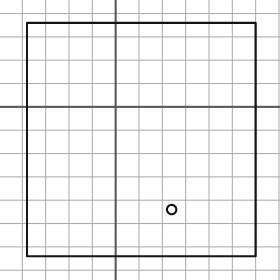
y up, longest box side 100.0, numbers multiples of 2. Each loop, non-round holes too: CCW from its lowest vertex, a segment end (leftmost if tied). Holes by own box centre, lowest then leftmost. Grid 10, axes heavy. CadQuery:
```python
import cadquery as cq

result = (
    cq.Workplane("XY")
    .moveTo(-38.0, -64.0)
    .lineTo(60.0, -64.0)
    .lineTo(60.0, 36.0)
    .lineTo(-38.0, 36.0)
    .close()
    .moveTo(24.0, -44.0)
    .circle(2.0)
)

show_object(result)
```